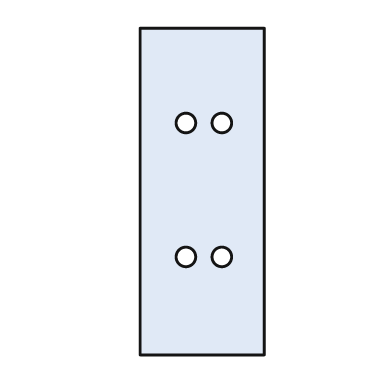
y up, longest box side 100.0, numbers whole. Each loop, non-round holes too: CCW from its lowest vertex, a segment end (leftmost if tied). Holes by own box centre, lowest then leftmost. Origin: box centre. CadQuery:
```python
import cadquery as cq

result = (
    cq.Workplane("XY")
    .moveTo(-19.0, -50.0)
    .lineTo(19.0, -50.0)
    .lineTo(19.0, 50.0)
    .lineTo(-19.0, 50.0)
    .close()
    .moveTo(-5.0, -20.0)
    .circle(3.0)
    .moveTo(6.0, -20.0)
    .circle(3.0)
    .moveTo(-5.0, 21.0)
    .circle(3.0)
    .moveTo(6.0, 21.0)
    .circle(3.0)
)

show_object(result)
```